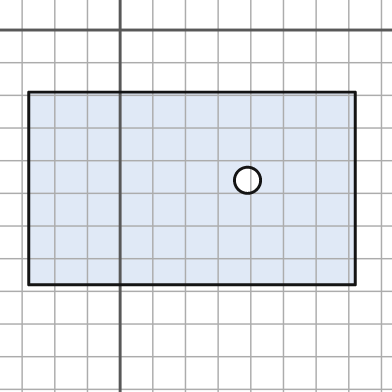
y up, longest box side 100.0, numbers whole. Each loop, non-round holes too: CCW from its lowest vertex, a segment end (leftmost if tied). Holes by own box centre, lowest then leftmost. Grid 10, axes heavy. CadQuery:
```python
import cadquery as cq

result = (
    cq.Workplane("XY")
    .moveTo(-28.0, -78.0)
    .lineTo(72.0, -78.0)
    .lineTo(72.0, -19.0)
    .lineTo(-28.0, -19.0)
    .close()
    .moveTo(39.0, -46.0)
    .circle(4.0)
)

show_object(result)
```